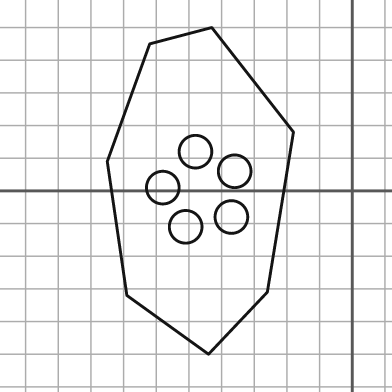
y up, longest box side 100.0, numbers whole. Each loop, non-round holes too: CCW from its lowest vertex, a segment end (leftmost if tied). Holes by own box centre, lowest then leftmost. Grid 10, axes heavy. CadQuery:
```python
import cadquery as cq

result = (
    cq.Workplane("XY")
    .moveTo(-44.0, -50.0)
    .lineTo(-26.0, -31.0)
    .lineTo(-18.0, 18.0)
    .lineTo(-43.0, 50.0)
    .lineTo(-62.0, 45.0)
    .lineTo(-75.0, 9.0)
    .lineTo(-69.0, -32.0)
    .close()
    .moveTo(-51.0, -11.0)
    .circle(5.0)
    .moveTo(-37.0, -8.0)
    .circle(5.0)
    .moveTo(-58.0, 1.0)
    .circle(5.0)
    .moveTo(-36.0, 6.0)
    .circle(5.0)
    .moveTo(-48.0, 12.0)
    .circle(5.0)
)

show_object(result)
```